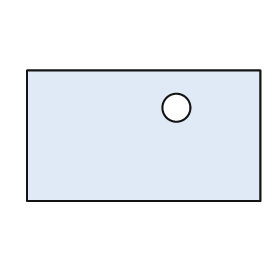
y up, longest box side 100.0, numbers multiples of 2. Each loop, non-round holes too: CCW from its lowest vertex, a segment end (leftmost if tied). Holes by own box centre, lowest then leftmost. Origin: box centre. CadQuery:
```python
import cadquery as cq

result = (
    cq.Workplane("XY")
    .moveTo(-50.0, -28.0)
    .lineTo(50.0, -28.0)
    .lineTo(50.0, 28.0)
    .lineTo(-50.0, 28.0)
    .close()
    .moveTo(14.0, 12.0)
    .circle(6.0)
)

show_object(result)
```